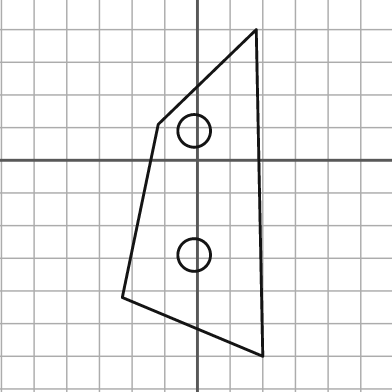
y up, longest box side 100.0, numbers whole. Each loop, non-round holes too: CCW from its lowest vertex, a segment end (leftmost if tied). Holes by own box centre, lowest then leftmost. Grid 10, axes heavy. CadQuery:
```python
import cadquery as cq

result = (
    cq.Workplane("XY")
    .moveTo(20.0, -60.0)
    .lineTo(18.0, 40.0)
    .lineTo(-12.0, 11.0)
    .lineTo(-23.0, -42.0)
    .close()
    .moveTo(-1.0, -29.0)
    .circle(5.0)
    .moveTo(-1.0, 9.0)
    .circle(5.0)
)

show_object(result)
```